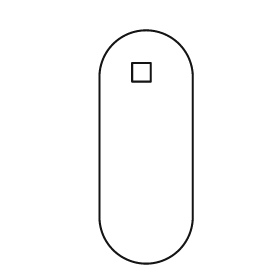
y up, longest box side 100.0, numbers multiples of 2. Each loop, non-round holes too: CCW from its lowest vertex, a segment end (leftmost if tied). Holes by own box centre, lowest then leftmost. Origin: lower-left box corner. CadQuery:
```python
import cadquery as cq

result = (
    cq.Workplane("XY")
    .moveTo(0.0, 20.0)
    .threePointArc((20.0, 0.0), (40.0, 20.0))
    .lineTo(40.0, 80.0)
    .threePointArc((20.0, 100.0), (0.0, 80.0))
    .close()
    .moveTo(14.0, 78.0)
    .lineTo(22.0, 78.0)
    .lineTo(22.0, 86.0)
    .lineTo(14.0, 86.0)
    .close()
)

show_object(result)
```